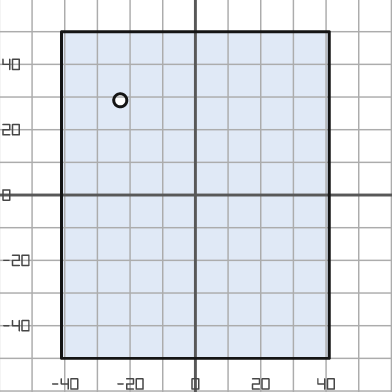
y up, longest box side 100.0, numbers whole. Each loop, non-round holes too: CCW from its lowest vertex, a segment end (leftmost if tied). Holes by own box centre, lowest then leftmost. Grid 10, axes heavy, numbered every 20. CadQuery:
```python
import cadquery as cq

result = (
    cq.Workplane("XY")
    .moveTo(-41.0, -50.0)
    .lineTo(41.0, -50.0)
    .lineTo(41.0, 50.0)
    .lineTo(-41.0, 50.0)
    .close()
    .moveTo(-23.0, 29.0)
    .circle(2.0)
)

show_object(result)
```